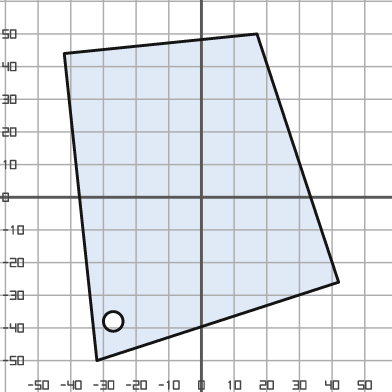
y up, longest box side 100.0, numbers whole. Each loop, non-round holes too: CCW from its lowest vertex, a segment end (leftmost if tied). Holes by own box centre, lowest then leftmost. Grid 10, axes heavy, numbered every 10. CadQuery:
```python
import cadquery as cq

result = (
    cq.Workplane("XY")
    .moveTo(-32.0, -50.0)
    .lineTo(42.0, -26.0)
    .lineTo(17.0, 50.0)
    .lineTo(-42.0, 44.0)
    .close()
    .moveTo(-27.0, -38.0)
    .circle(3.0)
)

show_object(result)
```